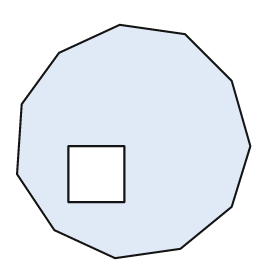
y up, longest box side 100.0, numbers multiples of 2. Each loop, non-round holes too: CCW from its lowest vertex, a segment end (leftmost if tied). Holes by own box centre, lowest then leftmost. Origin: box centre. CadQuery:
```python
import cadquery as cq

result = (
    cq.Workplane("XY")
    .moveTo(-8.0, -50.0)
    .lineTo(20.0, -46.0)
    .lineTo(42.0, -28.0)
    .lineTo(50.0, -2.0)
    .lineTo(42.0, 26.0)
    .lineTo(22.0, 46.0)
    .lineTo(-6.0, 50.0)
    .lineTo(-32.0, 38.0)
    .lineTo(-48.0, 16.0)
    .lineTo(-50.0, -14.0)
    .lineTo(-34.0, -38.0)
    .close()
    .moveTo(-28.0, -26.0)
    .lineTo(-4.0, -26.0)
    .lineTo(-4.0, -2.0)
    .lineTo(-28.0, -2.0)
    .close()
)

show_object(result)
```